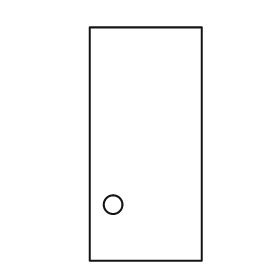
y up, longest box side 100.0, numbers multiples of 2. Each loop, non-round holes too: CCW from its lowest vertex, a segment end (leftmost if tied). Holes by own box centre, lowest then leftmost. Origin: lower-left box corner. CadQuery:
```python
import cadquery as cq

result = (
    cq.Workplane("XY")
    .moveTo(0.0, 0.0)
    .lineTo(48.0, 0.0)
    .lineTo(48.0, 100.0)
    .lineTo(0.0, 100.0)
    .close()
    .moveTo(10.0, 24.0)
    .circle(4.0)
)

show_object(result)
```